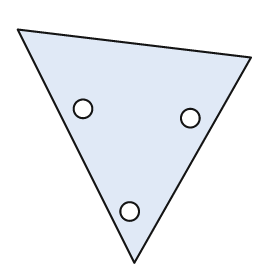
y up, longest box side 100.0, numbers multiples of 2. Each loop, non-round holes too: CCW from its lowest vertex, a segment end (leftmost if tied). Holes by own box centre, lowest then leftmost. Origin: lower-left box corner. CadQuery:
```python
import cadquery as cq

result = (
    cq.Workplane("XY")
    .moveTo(50.0, 0.0)
    .lineTo(100.0, 88.0)
    .lineTo(0.0, 100.0)
    .close()
    .moveTo(48.0, 22.0)
    .circle(4.0)
    .moveTo(74.0, 62.0)
    .circle(4.0)
    .moveTo(28.0, 66.0)
    .circle(4.0)
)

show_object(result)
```